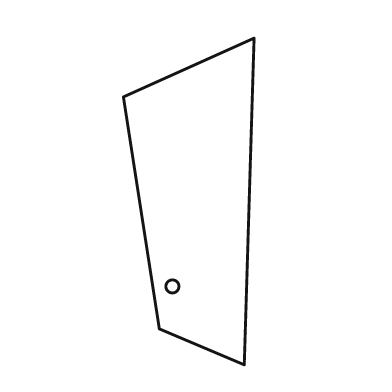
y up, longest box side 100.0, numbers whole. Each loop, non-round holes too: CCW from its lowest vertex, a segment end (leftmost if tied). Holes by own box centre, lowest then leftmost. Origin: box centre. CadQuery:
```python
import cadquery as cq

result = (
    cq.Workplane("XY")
    .moveTo(17.0, -50.0)
    .lineTo(20.0, 50.0)
    .lineTo(-20.0, 32.0)
    .lineTo(-9.0, -39.0)
    .close()
    .moveTo(-5.0, -26.0)
    .circle(2.0)
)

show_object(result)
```